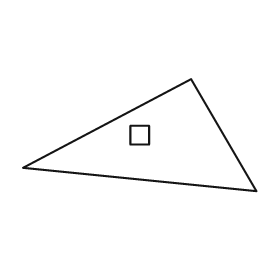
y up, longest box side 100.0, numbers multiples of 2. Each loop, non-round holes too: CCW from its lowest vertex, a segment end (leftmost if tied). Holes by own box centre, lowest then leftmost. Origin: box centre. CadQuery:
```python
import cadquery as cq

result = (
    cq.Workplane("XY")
    .moveTo(50.0, -24.0)
    .lineTo(22.0, 24.0)
    .lineTo(-50.0, -14.0)
    .close()
    .moveTo(-4.0, -4.0)
    .lineTo(4.0, -4.0)
    .lineTo(4.0, 4.0)
    .lineTo(-4.0, 4.0)
    .close()
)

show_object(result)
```